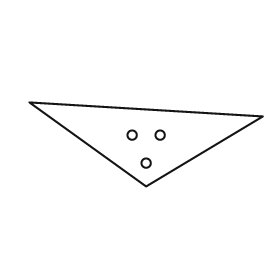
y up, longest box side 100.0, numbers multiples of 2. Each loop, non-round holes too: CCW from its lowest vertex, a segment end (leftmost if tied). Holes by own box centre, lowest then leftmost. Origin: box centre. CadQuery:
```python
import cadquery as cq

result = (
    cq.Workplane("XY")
    .moveTo(0.0, -18.0)
    .lineTo(50.0, 12.0)
    .lineTo(-50.0, 18.0)
    .close()
    .moveTo(0.0, -8.0)
    .circle(2.0)
    .moveTo(-6.0, 4.0)
    .circle(2.0)
    .moveTo(6.0, 4.0)
    .circle(2.0)
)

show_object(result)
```